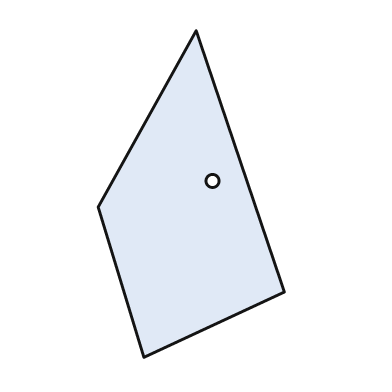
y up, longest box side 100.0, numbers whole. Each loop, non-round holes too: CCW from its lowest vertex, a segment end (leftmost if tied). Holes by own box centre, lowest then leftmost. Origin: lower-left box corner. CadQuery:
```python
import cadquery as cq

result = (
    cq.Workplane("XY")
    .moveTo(14.0, 0.0)
    .lineTo(57.0, 20.0)
    .lineTo(30.0, 100.0)
    .lineTo(0.0, 46.0)
    .close()
    .moveTo(35.0, 54.0)
    .circle(2.0)
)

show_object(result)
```